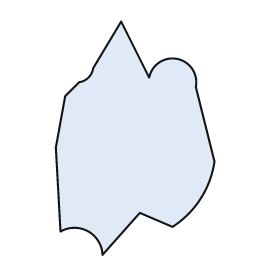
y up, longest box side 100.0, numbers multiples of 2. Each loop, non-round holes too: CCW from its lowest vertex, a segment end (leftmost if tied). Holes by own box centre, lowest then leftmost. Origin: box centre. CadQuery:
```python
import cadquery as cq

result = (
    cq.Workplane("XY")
    .moveTo(-14.0, -50.0)
    .lineTo(2.0, -32.0)
    .lineTo(16.0, -38.0)
    .threePointArc((28.0, -26.0), (34.0, -10.0))
    .lineTo(26.0, 22.0)
    .threePointArc((18.0, 34.0), (6.0, 26.0))
    .lineTo(-6.0, 50.0)
    .lineTo(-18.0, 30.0)
    .threePointArc((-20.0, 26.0), (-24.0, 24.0))
    .lineTo(-30.0, 18.0)
    .lineTo(-34.0, -4.0)
    .lineTo(-32.0, -40.0)
    .threePointArc((-20.0, -40.0), (-14.0, -50.0))
    .close()
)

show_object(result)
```